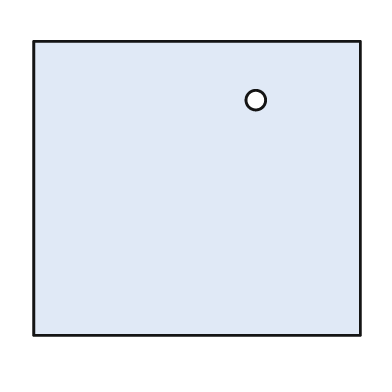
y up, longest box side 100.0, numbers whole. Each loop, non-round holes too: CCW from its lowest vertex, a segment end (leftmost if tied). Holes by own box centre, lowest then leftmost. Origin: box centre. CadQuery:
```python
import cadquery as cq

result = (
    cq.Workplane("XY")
    .moveTo(-50.0, -45.0)
    .lineTo(50.0, -45.0)
    .lineTo(50.0, 45.0)
    .lineTo(-50.0, 45.0)
    .close()
    .moveTo(18.0, 27.0)
    .circle(3.0)
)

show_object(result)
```